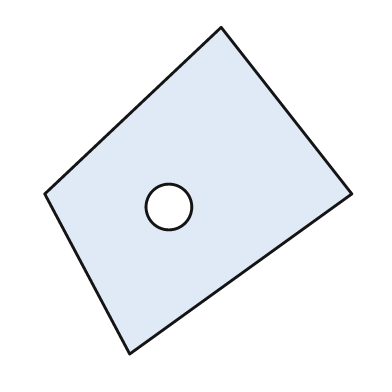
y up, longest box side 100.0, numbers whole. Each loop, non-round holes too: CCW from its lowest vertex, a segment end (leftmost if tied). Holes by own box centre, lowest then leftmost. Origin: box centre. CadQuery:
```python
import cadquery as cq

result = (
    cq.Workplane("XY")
    .moveTo(-21.0, -50.0)
    .lineTo(47.0, -1.0)
    .lineTo(7.0, 50.0)
    .lineTo(-47.0, -1.0)
    .close()
    .moveTo(-9.0, -5.0)
    .circle(7.0)
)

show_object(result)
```